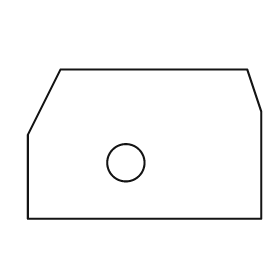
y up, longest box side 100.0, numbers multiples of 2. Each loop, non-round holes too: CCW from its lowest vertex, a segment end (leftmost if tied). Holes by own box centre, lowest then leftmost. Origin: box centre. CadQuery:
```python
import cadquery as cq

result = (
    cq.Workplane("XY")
    .moveTo(-50.0, -32.0)
    .lineTo(50.0, -32.0)
    .lineTo(50.0, 14.0)
    .lineTo(44.0, 32.0)
    .lineTo(-36.0, 32.0)
    .lineTo(-50.0, 4.0)
    .close()
    .moveTo(-8.0, -8.0)
    .circle(8.0)
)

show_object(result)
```